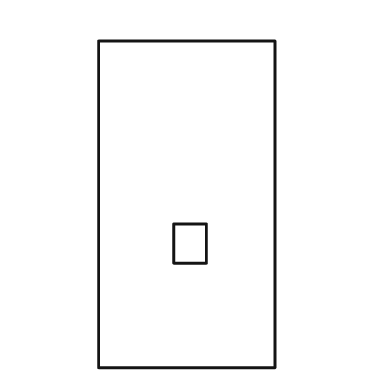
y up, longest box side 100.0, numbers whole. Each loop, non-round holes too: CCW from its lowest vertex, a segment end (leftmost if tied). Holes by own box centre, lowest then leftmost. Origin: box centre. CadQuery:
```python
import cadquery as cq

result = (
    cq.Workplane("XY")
    .moveTo(-27.0, -50.0)
    .lineTo(27.0, -50.0)
    .lineTo(27.0, 50.0)
    .lineTo(-27.0, 50.0)
    .close()
    .moveTo(-4.0, -18.0)
    .lineTo(6.0, -18.0)
    .lineTo(6.0, -6.0)
    .lineTo(-4.0, -6.0)
    .close()
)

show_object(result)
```